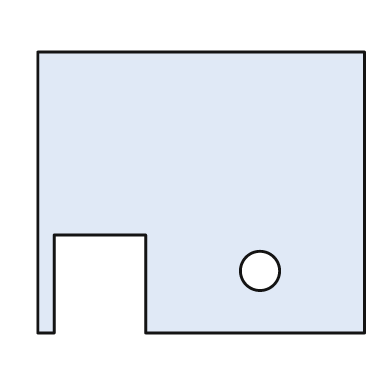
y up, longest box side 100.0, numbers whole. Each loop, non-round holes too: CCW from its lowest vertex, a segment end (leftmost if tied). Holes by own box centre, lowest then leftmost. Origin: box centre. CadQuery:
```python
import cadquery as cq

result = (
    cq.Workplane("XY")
    .moveTo(-50.0, -43.0)
    .lineTo(-45.0, -43.0)
    .lineTo(-45.0, -13.0)
    .lineTo(-17.0, -13.0)
    .lineTo(-17.0, -43.0)
    .lineTo(50.0, -43.0)
    .lineTo(50.0, 43.0)
    .lineTo(-50.0, 43.0)
    .close()
    .moveTo(18.0, -24.0)
    .circle(6.0)
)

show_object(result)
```